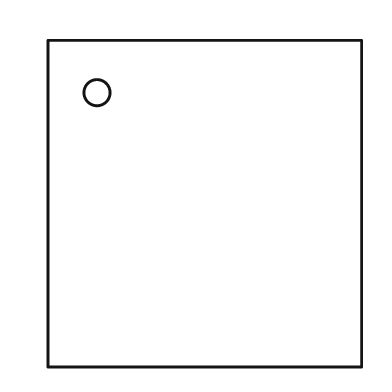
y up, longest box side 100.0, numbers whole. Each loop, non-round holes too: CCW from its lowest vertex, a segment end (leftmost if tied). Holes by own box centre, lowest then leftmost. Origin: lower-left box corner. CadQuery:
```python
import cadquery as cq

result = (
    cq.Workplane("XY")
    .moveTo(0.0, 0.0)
    .lineTo(96.0, 0.0)
    .lineTo(96.0, 100.0)
    .lineTo(0.0, 100.0)
    .close()
    .moveTo(15.0, 84.0)
    .circle(4.0)
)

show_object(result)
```